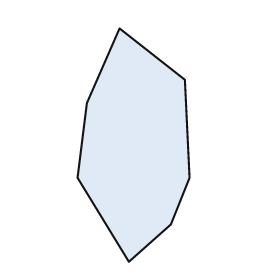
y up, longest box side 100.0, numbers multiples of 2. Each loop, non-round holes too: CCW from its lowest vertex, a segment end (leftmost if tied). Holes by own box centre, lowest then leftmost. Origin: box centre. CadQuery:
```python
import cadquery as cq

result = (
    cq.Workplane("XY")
    .moveTo(-2.0, -50.0)
    .lineTo(16.0, -34.0)
    .lineTo(24.0, -14.0)
    .lineTo(22.0, 28.0)
    .lineTo(-6.0, 50.0)
    .lineTo(-20.0, 18.0)
    .lineTo(-24.0, -14.0)
    .close()
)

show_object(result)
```